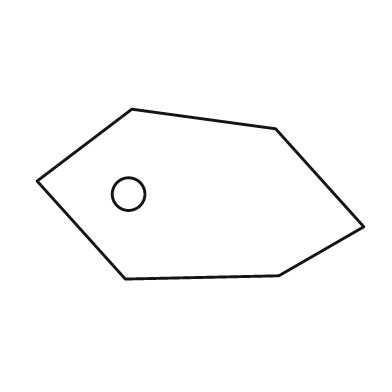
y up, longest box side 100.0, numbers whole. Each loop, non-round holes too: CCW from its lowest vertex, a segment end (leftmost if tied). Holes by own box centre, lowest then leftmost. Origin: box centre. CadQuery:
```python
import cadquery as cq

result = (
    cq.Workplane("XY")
    .moveTo(-23.0, -26.0)
    .lineTo(24.0, -25.0)
    .lineTo(50.0, -10.0)
    .lineTo(23.0, 20.0)
    .lineTo(-21.0, 26.0)
    .lineTo(-50.0, 4.0)
    .close()
    .moveTo(-22.0, 0.0)
    .circle(5.0)
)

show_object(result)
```